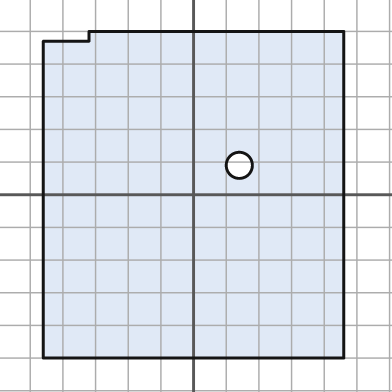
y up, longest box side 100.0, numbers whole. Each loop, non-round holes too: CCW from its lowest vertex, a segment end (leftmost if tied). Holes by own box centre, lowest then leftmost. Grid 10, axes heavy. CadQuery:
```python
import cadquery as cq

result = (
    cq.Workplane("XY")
    .moveTo(-46.0, -50.0)
    .lineTo(46.0, -50.0)
    .lineTo(46.0, 50.0)
    .lineTo(-32.0, 50.0)
    .lineTo(-32.0, 47.0)
    .lineTo(-46.0, 47.0)
    .close()
    .moveTo(14.0, 9.0)
    .circle(4.0)
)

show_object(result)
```